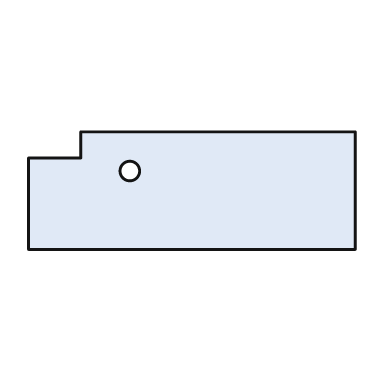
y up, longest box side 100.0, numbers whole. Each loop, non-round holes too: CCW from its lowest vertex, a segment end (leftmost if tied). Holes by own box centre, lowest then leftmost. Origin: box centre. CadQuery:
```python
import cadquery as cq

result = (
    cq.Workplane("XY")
    .moveTo(-50.0, -18.0)
    .lineTo(50.0, -18.0)
    .lineTo(50.0, 18.0)
    .lineTo(-34.0, 18.0)
    .lineTo(-34.0, 10.0)
    .lineTo(-50.0, 10.0)
    .close()
    .moveTo(-19.0, 6.0)
    .circle(3.0)
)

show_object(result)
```